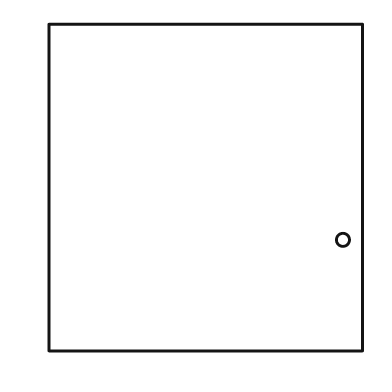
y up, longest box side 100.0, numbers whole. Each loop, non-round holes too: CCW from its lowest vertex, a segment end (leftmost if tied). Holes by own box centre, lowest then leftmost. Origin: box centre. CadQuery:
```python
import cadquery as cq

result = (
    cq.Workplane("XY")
    .moveTo(-48.0, -50.0)
    .lineTo(48.0, -50.0)
    .lineTo(48.0, 50.0)
    .lineTo(-48.0, 50.0)
    .close()
    .moveTo(42.0, -16.0)
    .circle(2.0)
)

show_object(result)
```